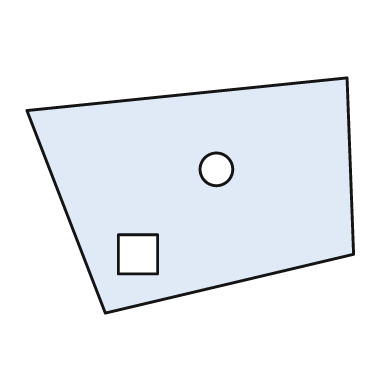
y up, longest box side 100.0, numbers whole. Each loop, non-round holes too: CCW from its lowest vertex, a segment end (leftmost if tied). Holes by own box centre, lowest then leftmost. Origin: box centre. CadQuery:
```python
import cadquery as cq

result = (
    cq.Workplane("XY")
    .moveTo(-26.0, -36.0)
    .lineTo(50.0, -18.0)
    .lineTo(48.0, 36.0)
    .lineTo(-50.0, 26.0)
    .close()
    .moveTo(-22.0, -24.0)
    .lineTo(-10.0, -24.0)
    .lineTo(-10.0, -12.0)
    .lineTo(-22.0, -12.0)
    .close()
    .moveTo(8.0, 8.0)
    .circle(5.0)
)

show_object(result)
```